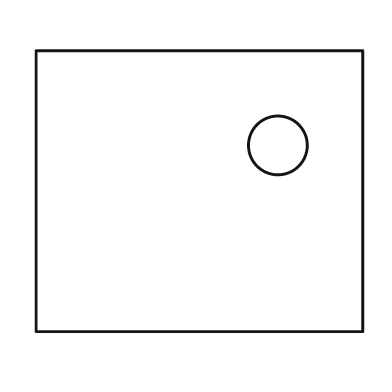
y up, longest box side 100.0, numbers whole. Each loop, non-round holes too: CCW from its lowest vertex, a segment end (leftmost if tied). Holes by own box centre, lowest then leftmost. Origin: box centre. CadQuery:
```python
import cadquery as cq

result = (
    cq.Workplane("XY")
    .moveTo(-50.0, -43.0)
    .lineTo(50.0, -43.0)
    .lineTo(50.0, 43.0)
    .lineTo(-50.0, 43.0)
    .close()
    .moveTo(24.0, 14.0)
    .circle(9.0)
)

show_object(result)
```